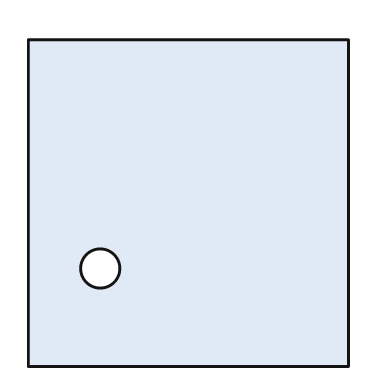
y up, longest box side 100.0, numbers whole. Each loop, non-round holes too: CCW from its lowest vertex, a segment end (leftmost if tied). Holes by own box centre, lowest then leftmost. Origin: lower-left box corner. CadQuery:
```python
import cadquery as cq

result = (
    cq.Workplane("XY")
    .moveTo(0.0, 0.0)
    .lineTo(98.0, 0.0)
    .lineTo(98.0, 100.0)
    .lineTo(0.0, 100.0)
    .close()
    .moveTo(22.0, 30.0)
    .circle(6.0)
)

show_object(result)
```